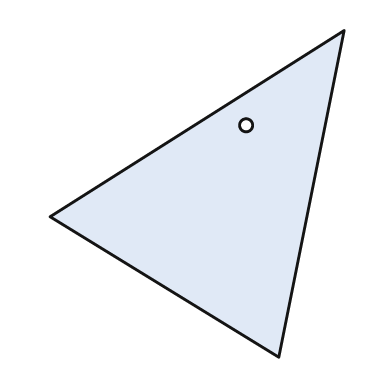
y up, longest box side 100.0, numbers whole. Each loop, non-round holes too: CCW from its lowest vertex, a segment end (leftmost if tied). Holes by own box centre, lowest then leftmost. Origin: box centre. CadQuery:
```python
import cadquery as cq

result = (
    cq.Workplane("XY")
    .moveTo(25.0, -50.0)
    .lineTo(45.0, 50.0)
    .lineTo(-45.0, -7.0)
    .close()
    .moveTo(15.0, 21.0)
    .circle(2.0)
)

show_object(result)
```